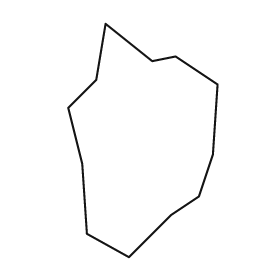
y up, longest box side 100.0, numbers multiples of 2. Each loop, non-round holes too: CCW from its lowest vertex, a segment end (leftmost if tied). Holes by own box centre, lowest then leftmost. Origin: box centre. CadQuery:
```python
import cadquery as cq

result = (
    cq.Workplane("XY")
    .moveTo(-6.0, -50.0)
    .lineTo(12.0, -32.0)
    .lineTo(24.0, -24.0)
    .lineTo(30.0, -6.0)
    .lineTo(32.0, 24.0)
    .lineTo(14.0, 36.0)
    .lineTo(4.0, 34.0)
    .lineTo(-16.0, 50.0)
    .lineTo(-20.0, 26.0)
    .lineTo(-32.0, 14.0)
    .lineTo(-26.0, -10.0)
    .lineTo(-24.0, -40.0)
    .close()
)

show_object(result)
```